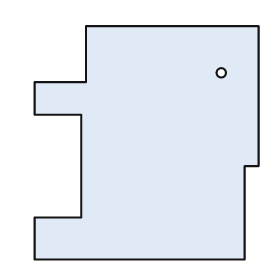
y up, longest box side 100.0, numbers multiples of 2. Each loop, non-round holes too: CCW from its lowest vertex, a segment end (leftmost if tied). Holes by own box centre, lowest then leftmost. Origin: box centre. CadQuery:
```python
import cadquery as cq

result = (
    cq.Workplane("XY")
    .moveTo(-48.0, -50.0)
    .lineTo(42.0, -50.0)
    .lineTo(42.0, -10.0)
    .lineTo(48.0, -10.0)
    .lineTo(48.0, 50.0)
    .lineTo(-26.0, 50.0)
    .lineTo(-26.0, 26.0)
    .lineTo(-48.0, 26.0)
    .lineTo(-48.0, 12.0)
    .lineTo(-28.0, 12.0)
    .lineTo(-28.0, -32.0)
    .lineTo(-48.0, -32.0)
    .close()
    .moveTo(32.0, 30.0)
    .circle(2.0)
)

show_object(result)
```